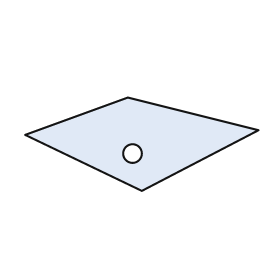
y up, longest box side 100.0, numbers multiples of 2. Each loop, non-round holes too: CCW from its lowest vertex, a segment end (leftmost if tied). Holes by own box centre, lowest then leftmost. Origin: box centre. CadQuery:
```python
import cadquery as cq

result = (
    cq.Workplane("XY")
    .moveTo(0.0, -20.0)
    .lineTo(50.0, 6.0)
    .lineTo(-6.0, 20.0)
    .lineTo(-50.0, 4.0)
    .close()
    .moveTo(-4.0, -4.0)
    .circle(4.0)
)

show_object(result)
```